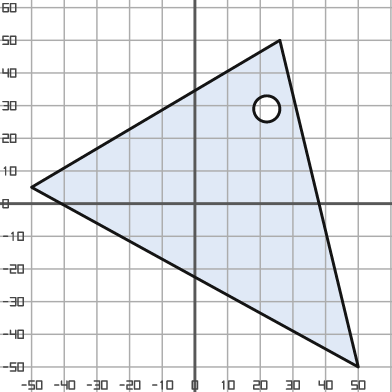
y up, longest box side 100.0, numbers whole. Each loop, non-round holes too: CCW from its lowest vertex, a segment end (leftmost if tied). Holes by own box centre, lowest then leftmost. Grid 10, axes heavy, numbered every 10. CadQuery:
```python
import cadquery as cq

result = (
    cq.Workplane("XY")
    .moveTo(50.0, -50.0)
    .lineTo(26.0, 50.0)
    .lineTo(-50.0, 5.0)
    .close()
    .moveTo(22.0, 29.0)
    .circle(4.0)
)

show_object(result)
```